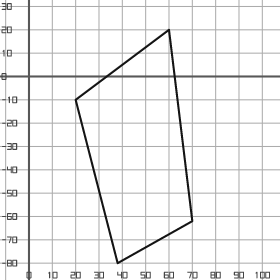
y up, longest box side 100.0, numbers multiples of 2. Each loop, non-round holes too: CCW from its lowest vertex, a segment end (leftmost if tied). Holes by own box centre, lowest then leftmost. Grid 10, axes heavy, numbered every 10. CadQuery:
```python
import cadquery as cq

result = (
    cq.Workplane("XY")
    .moveTo(38.0, -80.0)
    .lineTo(70.0, -62.0)
    .lineTo(60.0, 20.0)
    .lineTo(20.0, -10.0)
    .close()
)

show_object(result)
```